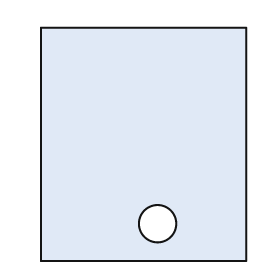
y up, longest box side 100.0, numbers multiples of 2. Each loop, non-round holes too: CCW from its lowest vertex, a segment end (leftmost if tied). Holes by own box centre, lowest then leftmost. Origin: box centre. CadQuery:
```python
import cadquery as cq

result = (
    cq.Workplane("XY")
    .moveTo(-44.0, -50.0)
    .lineTo(44.0, -50.0)
    .lineTo(44.0, 50.0)
    .lineTo(-44.0, 50.0)
    .close()
    .moveTo(6.0, -34.0)
    .circle(8.0)
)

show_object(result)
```